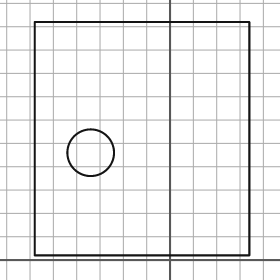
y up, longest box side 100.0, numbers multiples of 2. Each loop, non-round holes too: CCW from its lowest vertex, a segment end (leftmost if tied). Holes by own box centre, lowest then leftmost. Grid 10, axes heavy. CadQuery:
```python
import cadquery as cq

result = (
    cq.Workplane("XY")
    .moveTo(-58.0, 2.0)
    .lineTo(34.0, 2.0)
    .lineTo(34.0, 102.0)
    .lineTo(-58.0, 102.0)
    .close()
    .moveTo(-34.0, 46.0)
    .circle(10.0)
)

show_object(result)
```